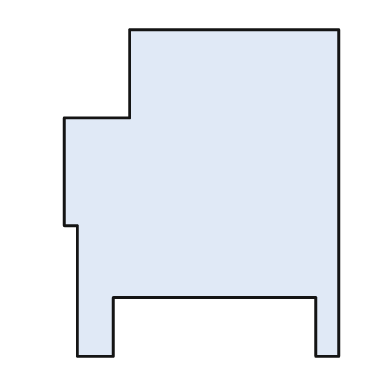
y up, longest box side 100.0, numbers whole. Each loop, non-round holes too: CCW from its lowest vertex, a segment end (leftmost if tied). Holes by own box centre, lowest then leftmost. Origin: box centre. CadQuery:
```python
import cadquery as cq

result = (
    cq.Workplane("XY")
    .moveTo(-38.0, -50.0)
    .lineTo(-27.0, -50.0)
    .lineTo(-27.0, -32.0)
    .lineTo(35.0, -32.0)
    .lineTo(35.0, -50.0)
    .lineTo(42.0, -50.0)
    .lineTo(42.0, 50.0)
    .lineTo(-22.0, 50.0)
    .lineTo(-22.0, 23.0)
    .lineTo(-42.0, 23.0)
    .lineTo(-42.0, -10.0)
    .lineTo(-38.0, -10.0)
    .close()
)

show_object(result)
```